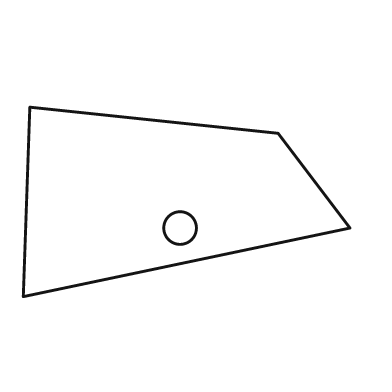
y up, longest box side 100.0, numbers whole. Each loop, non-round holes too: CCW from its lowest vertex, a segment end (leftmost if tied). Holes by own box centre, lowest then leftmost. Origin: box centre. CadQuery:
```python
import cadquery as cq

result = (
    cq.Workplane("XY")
    .moveTo(-50.0, -29.0)
    .lineTo(50.0, -8.0)
    .lineTo(28.0, 21.0)
    .lineTo(-48.0, 29.0)
    .close()
    .moveTo(-2.0, -8.0)
    .circle(5.0)
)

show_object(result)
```